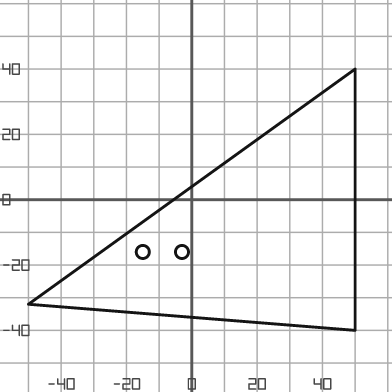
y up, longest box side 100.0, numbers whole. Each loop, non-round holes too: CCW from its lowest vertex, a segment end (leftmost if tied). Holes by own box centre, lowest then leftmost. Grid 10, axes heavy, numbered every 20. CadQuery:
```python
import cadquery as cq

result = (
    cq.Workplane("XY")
    .moveTo(50.0, -40.0)
    .lineTo(50.0, 40.0)
    .lineTo(-50.0, -32.0)
    .close()
    .moveTo(-15.0, -16.0)
    .circle(2.0)
    .moveTo(-3.0, -16.0)
    .circle(2.0)
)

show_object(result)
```